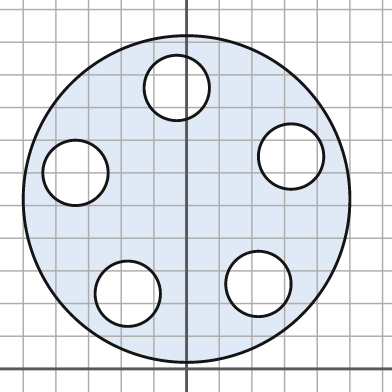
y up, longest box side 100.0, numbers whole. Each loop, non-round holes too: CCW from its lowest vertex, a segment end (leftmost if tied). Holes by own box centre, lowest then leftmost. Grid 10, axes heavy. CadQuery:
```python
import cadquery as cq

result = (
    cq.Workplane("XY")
    .moveTo(0.0, 52.0)
    .circle(50.0)
    .moveTo(-18.0, 23.0)
    .circle(10.0)
    .moveTo(22.0, 26.0)
    .circle(10.0)
    .moveTo(-34.0, 60.0)
    .circle(10.0)
    .moveTo(32.0, 65.0)
    .circle(10.0)
    .moveTo(-3.0, 86.0)
    .circle(10.0)
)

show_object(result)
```